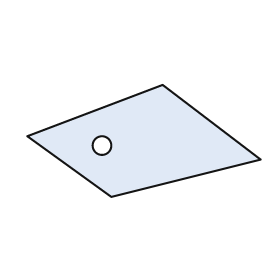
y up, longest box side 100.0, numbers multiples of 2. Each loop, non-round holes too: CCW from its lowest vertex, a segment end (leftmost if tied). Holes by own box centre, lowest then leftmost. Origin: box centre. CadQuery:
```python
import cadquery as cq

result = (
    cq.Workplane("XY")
    .moveTo(-14.0, -24.0)
    .lineTo(50.0, -8.0)
    .lineTo(8.0, 24.0)
    .lineTo(-50.0, 2.0)
    .close()
    .moveTo(-18.0, -2.0)
    .circle(4.0)
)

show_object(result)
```